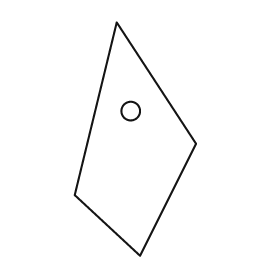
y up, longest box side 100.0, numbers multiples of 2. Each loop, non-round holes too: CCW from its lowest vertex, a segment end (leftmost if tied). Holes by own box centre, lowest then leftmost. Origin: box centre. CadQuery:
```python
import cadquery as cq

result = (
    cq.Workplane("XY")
    .moveTo(2.0, -50.0)
    .lineTo(26.0, -2.0)
    .lineTo(-8.0, 50.0)
    .lineTo(-26.0, -24.0)
    .close()
    .moveTo(-2.0, 12.0)
    .circle(4.0)
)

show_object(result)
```